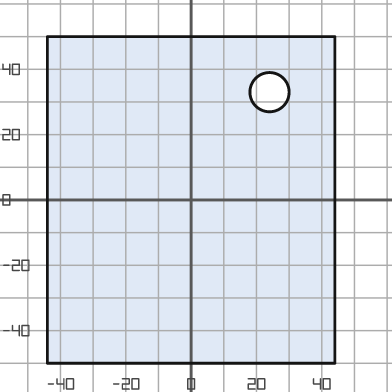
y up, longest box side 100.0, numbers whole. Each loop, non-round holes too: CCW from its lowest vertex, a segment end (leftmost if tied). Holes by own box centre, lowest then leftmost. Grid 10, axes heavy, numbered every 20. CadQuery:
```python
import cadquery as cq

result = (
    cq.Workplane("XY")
    .moveTo(-44.0, -50.0)
    .lineTo(44.0, -50.0)
    .lineTo(44.0, 50.0)
    .lineTo(-44.0, 50.0)
    .close()
    .moveTo(24.0, 33.0)
    .circle(6.0)
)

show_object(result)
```